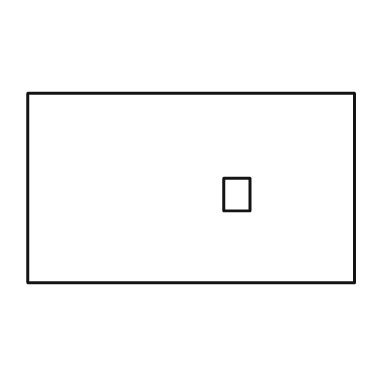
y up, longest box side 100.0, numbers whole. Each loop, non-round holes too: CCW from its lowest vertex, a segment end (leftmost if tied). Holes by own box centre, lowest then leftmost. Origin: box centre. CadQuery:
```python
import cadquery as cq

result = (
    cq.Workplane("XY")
    .moveTo(-50.0, -29.0)
    .lineTo(50.0, -29.0)
    .lineTo(50.0, 29.0)
    .lineTo(-50.0, 29.0)
    .close()
    .moveTo(10.0, -7.0)
    .lineTo(18.0, -7.0)
    .lineTo(18.0, 3.0)
    .lineTo(10.0, 3.0)
    .close()
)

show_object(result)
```